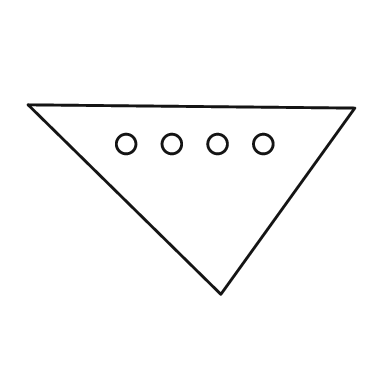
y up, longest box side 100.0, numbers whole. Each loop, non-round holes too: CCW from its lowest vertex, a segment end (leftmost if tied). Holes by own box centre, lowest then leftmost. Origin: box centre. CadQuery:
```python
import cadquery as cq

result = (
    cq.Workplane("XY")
    .moveTo(9.0, -29.0)
    .lineTo(50.0, 28.0)
    .lineTo(-50.0, 29.0)
    .close()
    .moveTo(-20.0, 17.0)
    .circle(3.0)
    .moveTo(-6.0, 17.0)
    .circle(3.0)
    .moveTo(8.0, 17.0)
    .circle(3.0)
    .moveTo(22.0, 17.0)
    .circle(3.0)
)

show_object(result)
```